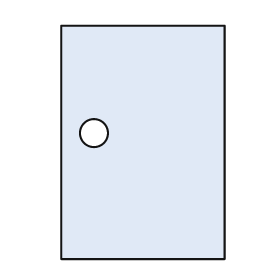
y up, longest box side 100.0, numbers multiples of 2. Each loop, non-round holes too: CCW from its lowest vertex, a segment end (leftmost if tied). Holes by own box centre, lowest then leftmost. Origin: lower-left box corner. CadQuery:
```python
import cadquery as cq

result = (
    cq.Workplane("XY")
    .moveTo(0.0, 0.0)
    .lineTo(70.0, 0.0)
    .lineTo(70.0, 100.0)
    .lineTo(0.0, 100.0)
    .close()
    .moveTo(14.0, 54.0)
    .circle(6.0)
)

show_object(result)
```